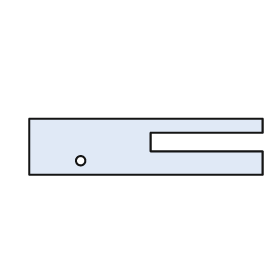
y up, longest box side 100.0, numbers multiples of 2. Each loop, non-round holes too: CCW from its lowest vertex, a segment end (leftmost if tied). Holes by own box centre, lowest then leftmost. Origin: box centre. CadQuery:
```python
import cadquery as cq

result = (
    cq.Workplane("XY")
    .moveTo(-50.0, -12.0)
    .lineTo(50.0, -12.0)
    .lineTo(50.0, -2.0)
    .lineTo(2.0, -2.0)
    .lineTo(2.0, 6.0)
    .lineTo(50.0, 6.0)
    .lineTo(50.0, 12.0)
    .lineTo(-50.0, 12.0)
    .close()
    .moveTo(-28.0, -6.0)
    .circle(2.0)
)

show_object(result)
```